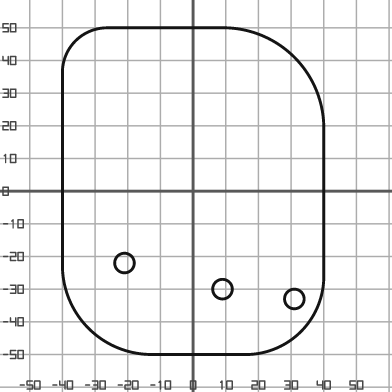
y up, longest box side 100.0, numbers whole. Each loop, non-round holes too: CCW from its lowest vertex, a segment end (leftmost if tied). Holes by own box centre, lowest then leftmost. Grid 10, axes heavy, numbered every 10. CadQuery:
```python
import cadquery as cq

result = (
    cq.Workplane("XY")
    .moveTo(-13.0, -50.0)
    .lineTo(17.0, -50.0)
    .threePointArc((33.0, -43.0), (40.0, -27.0))
    .lineTo(40.0, 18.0)
    .threePointArc((31.0, 41.0), (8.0, 50.0))
    .lineTo(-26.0, 50.0)
    .threePointArc((-36.0, 46.0), (-40.0, 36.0))
    .lineTo(-40.0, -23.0)
    .threePointArc((-32.0, -42.0), (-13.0, -50.0))
    .close()
    .moveTo(31.0, -33.0)
    .circle(3.0)
    .moveTo(9.0, -30.0)
    .circle(3.0)
    .moveTo(-21.0, -22.0)
    .circle(3.0)
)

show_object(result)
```